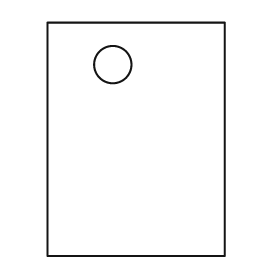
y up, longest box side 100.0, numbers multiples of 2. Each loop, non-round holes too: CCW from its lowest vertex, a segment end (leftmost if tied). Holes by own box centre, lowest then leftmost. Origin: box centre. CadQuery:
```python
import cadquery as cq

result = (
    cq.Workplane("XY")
    .moveTo(-38.0, -50.0)
    .lineTo(38.0, -50.0)
    .lineTo(38.0, 50.0)
    .lineTo(-38.0, 50.0)
    .close()
    .moveTo(-10.0, 32.0)
    .circle(8.0)
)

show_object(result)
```